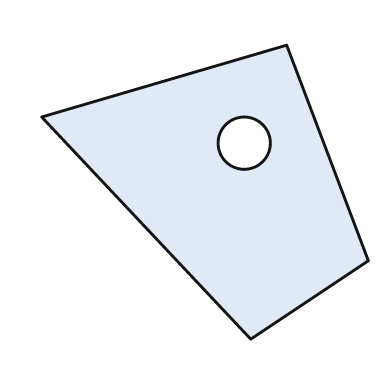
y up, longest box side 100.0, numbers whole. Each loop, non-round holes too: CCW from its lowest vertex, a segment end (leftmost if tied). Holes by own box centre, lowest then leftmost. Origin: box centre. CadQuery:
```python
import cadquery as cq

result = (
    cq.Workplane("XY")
    .moveTo(14.0, -45.0)
    .lineTo(50.0, -21.0)
    .lineTo(25.0, 45.0)
    .lineTo(-50.0, 23.0)
    .close()
    .moveTo(12.0, 15.0)
    .circle(8.0)
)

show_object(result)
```